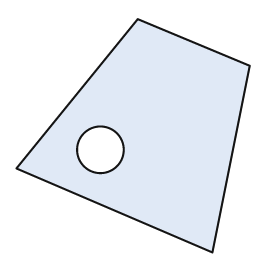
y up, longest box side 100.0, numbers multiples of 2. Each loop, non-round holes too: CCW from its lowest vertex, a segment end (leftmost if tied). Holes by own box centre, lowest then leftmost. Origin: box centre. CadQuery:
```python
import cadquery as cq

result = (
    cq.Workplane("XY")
    .moveTo(34.0, -50.0)
    .lineTo(50.0, 30.0)
    .lineTo(2.0, 50.0)
    .lineTo(-50.0, -14.0)
    .close()
    .moveTo(-14.0, -6.0)
    .circle(10.0)
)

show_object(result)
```